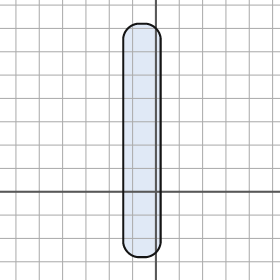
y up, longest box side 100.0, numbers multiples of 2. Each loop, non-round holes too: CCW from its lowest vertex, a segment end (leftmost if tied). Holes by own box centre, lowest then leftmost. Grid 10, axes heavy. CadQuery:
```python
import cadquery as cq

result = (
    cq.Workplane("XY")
    .moveTo(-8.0, -28.0)
    .lineTo(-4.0, -28.0)
    .threePointArc((0.0, -26.0), (2.0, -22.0))
    .lineTo(2.0, 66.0)
    .threePointArc((0.0, 70.0), (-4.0, 72.0))
    .lineTo(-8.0, 72.0)
    .threePointArc((-12.0, 70.0), (-14.0, 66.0))
    .lineTo(-14.0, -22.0)
    .threePointArc((-12.0, -26.0), (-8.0, -28.0))
    .close()
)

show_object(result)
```